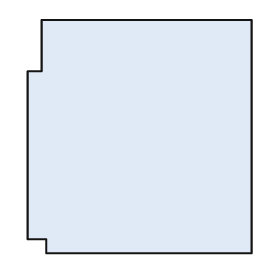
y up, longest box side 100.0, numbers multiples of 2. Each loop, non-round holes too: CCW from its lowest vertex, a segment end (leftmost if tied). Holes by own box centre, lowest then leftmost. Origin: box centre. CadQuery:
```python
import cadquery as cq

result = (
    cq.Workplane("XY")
    .moveTo(-40.0, -50.0)
    .lineTo(48.0, -50.0)
    .lineTo(48.0, 50.0)
    .lineTo(-42.0, 50.0)
    .lineTo(-42.0, 28.0)
    .lineTo(-48.0, 28.0)
    .lineTo(-48.0, -44.0)
    .lineTo(-40.0, -44.0)
    .close()
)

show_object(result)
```